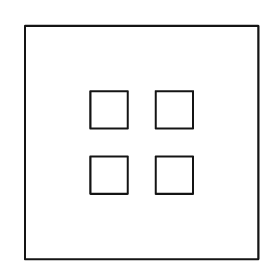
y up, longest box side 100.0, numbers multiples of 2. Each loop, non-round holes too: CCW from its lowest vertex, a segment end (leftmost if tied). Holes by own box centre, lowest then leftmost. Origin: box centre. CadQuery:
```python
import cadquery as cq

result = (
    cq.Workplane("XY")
    .moveTo(-50.0, -50.0)
    .lineTo(50.0, -50.0)
    .lineTo(50.0, 50.0)
    .lineTo(-50.0, 50.0)
    .close()
    .moveTo(-22.0, -22.0)
    .lineTo(-6.0, -22.0)
    .lineTo(-6.0, -6.0)
    .lineTo(-22.0, -6.0)
    .close()
    .moveTo(6.0, -22.0)
    .lineTo(22.0, -22.0)
    .lineTo(22.0, -6.0)
    .lineTo(6.0, -6.0)
    .close()
    .moveTo(-22.0, 6.0)
    .lineTo(-6.0, 6.0)
    .lineTo(-6.0, 22.0)
    .lineTo(-22.0, 22.0)
    .close()
    .moveTo(6.0, 6.0)
    .lineTo(22.0, 6.0)
    .lineTo(22.0, 22.0)
    .lineTo(6.0, 22.0)
    .close()
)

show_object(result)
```